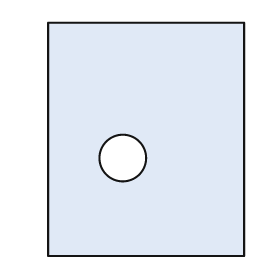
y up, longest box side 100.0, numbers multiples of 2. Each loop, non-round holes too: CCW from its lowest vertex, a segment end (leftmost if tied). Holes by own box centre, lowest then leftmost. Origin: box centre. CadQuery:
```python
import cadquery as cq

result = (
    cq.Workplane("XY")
    .moveTo(-42.0, -50.0)
    .lineTo(42.0, -50.0)
    .lineTo(42.0, 50.0)
    .lineTo(-42.0, 50.0)
    .close()
    .moveTo(-10.0, -8.0)
    .circle(10.0)
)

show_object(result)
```